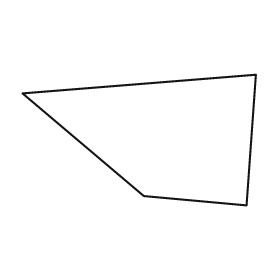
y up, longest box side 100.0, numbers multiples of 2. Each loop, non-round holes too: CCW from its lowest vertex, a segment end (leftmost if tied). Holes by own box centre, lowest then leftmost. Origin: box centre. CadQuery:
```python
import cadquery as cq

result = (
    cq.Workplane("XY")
    .moveTo(46.0, -28.0)
    .lineTo(50.0, 28.0)
    .lineTo(-50.0, 20.0)
    .lineTo(2.0, -24.0)
    .close()
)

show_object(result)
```